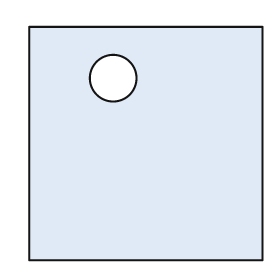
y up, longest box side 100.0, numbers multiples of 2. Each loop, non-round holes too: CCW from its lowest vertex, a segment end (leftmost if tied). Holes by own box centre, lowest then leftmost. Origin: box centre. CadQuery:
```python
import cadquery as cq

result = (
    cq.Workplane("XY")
    .moveTo(-50.0, -50.0)
    .lineTo(50.0, -50.0)
    .lineTo(50.0, 50.0)
    .lineTo(-50.0, 50.0)
    .close()
    .moveTo(-14.0, 28.0)
    .circle(10.0)
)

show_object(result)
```